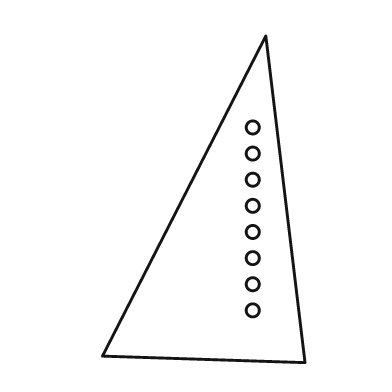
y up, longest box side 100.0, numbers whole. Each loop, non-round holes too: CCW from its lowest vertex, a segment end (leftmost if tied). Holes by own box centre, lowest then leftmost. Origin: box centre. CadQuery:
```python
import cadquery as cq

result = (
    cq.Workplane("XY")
    .moveTo(31.0, -50.0)
    .lineTo(19.0, 50.0)
    .lineTo(-31.0, -48.0)
    .close()
    .moveTo(15.0, -34.0)
    .circle(2.0)
    .moveTo(15.0, -26.0)
    .circle(2.0)
    .moveTo(15.0, -18.0)
    .circle(2.0)
    .moveTo(15.0, -10.0)
    .circle(2.0)
    .moveTo(15.0, -2.0)
    .circle(2.0)
    .moveTo(15.0, 6.0)
    .circle(2.0)
    .moveTo(15.0, 14.0)
    .circle(2.0)
    .moveTo(15.0, 22.0)
    .circle(2.0)
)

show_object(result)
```